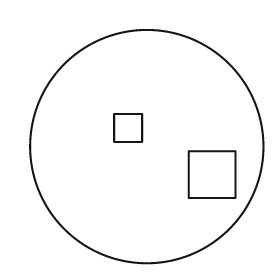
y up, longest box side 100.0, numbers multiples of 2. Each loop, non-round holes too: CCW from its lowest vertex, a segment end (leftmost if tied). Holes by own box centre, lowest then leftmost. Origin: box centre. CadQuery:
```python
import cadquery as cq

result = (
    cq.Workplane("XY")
    .moveTo(0.0, 0.0)
    .circle(50.0)
    .moveTo(18.0, -22.0)
    .lineTo(38.0, -22.0)
    .lineTo(38.0, -2.0)
    .lineTo(18.0, -2.0)
    .close()
    .moveTo(-14.0, 2.0)
    .lineTo(-2.0, 2.0)
    .lineTo(-2.0, 14.0)
    .lineTo(-14.0, 14.0)
    .close()
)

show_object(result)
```